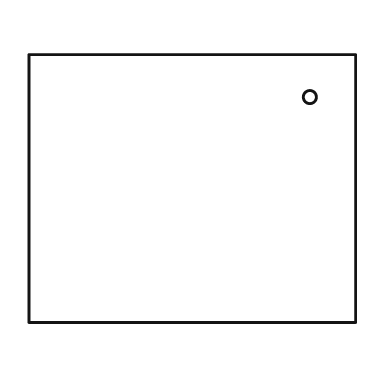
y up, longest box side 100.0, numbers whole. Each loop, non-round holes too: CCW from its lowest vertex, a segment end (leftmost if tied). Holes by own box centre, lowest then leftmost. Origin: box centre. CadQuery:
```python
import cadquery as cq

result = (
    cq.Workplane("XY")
    .moveTo(-50.0, -41.0)
    .lineTo(50.0, -41.0)
    .lineTo(50.0, 41.0)
    .lineTo(-50.0, 41.0)
    .close()
    .moveTo(36.0, 28.0)
    .circle(2.0)
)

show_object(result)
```